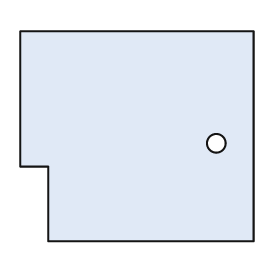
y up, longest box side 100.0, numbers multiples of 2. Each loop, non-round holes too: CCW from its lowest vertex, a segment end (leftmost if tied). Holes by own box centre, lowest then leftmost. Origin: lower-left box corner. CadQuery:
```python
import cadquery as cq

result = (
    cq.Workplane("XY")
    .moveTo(12.0, 0.0)
    .lineTo(100.0, 0.0)
    .lineTo(100.0, 90.0)
    .lineTo(0.0, 90.0)
    .lineTo(0.0, 32.0)
    .lineTo(12.0, 32.0)
    .close()
    .moveTo(84.0, 42.0)
    .circle(4.0)
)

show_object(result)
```